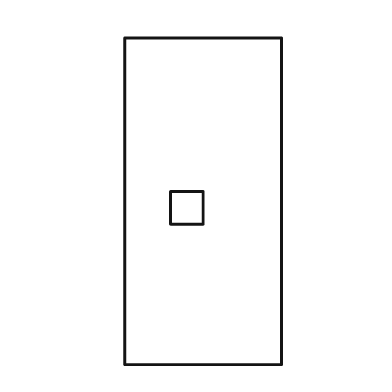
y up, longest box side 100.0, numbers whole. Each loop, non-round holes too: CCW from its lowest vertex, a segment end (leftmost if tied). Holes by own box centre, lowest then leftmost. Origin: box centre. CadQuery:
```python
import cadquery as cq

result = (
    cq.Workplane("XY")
    .moveTo(-24.0, -50.0)
    .lineTo(24.0, -50.0)
    .lineTo(24.0, 50.0)
    .lineTo(-24.0, 50.0)
    .close()
    .moveTo(-10.0, -7.0)
    .lineTo(0.0, -7.0)
    .lineTo(0.0, 3.0)
    .lineTo(-10.0, 3.0)
    .close()
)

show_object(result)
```